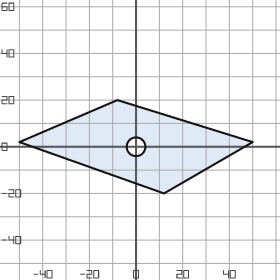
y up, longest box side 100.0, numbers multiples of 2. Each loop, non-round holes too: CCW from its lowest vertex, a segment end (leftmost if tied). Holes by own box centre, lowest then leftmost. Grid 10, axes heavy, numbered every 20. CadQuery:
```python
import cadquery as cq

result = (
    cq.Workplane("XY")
    .moveTo(12.0, -20.0)
    .lineTo(50.0, 2.0)
    .lineTo(-8.0, 20.0)
    .lineTo(-50.0, 2.0)
    .close()
    .moveTo(0.0, 0.0)
    .circle(4.0)
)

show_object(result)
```